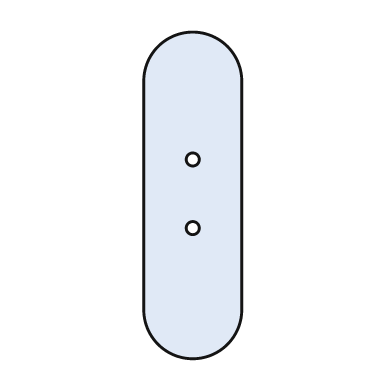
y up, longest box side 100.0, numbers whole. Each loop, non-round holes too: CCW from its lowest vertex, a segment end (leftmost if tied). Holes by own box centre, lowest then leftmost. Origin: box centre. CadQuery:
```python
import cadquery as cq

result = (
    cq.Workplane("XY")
    .moveTo(-15.0, -35.0)
    .threePointArc((0.0, -50.0), (15.0, -35.0))
    .lineTo(15.0, 35.0)
    .threePointArc((0.0, 50.0), (-15.0, 35.0))
    .close()
    .moveTo(0.0, -10.0)
    .circle(2.0)
    .moveTo(0.0, 11.0)
    .circle(2.0)
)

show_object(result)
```